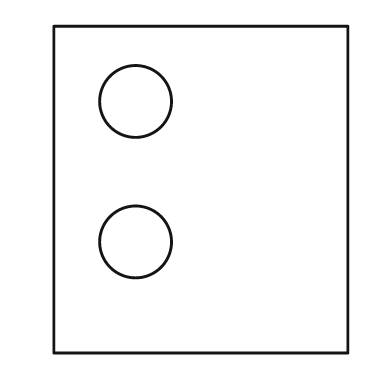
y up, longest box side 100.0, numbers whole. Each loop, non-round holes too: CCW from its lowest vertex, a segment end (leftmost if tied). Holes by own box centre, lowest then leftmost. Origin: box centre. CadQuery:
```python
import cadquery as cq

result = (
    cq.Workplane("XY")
    .moveTo(-45.0, -50.0)
    .lineTo(45.0, -50.0)
    .lineTo(45.0, 50.0)
    .lineTo(-45.0, 50.0)
    .close()
    .moveTo(-20.0, -16.0)
    .circle(11.0)
    .moveTo(-20.0, 27.0)
    .circle(11.0)
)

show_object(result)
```